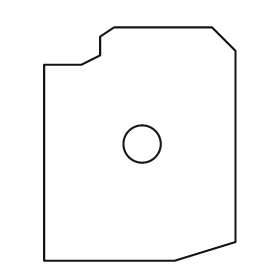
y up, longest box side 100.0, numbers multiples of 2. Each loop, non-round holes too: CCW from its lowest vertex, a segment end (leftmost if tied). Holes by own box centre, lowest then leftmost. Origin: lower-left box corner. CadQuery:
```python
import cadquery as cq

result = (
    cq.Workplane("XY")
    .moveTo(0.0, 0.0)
    .lineTo(56.0, 0.0)
    .lineTo(82.0, 8.0)
    .lineTo(82.0, 90.0)
    .lineTo(72.0, 100.0)
    .lineTo(30.0, 100.0)
    .lineTo(24.0, 96.0)
    .lineTo(24.0, 88.0)
    .lineTo(16.0, 84.0)
    .lineTo(0.0, 84.0)
    .close()
    .moveTo(42.0, 50.0)
    .circle(8.0)
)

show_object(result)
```